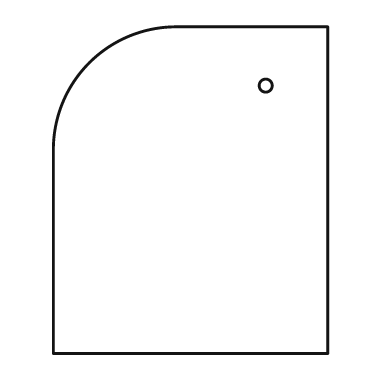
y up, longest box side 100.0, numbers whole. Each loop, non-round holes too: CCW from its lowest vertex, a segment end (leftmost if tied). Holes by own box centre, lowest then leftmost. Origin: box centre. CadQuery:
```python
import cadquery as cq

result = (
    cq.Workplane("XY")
    .moveTo(-42.0, -50.0)
    .lineTo(42.0, -50.0)
    .lineTo(42.0, 50.0)
    .lineTo(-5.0, 50.0)
    .threePointArc((-31.0, 39.0), (-42.0, 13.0))
    .close()
    .moveTo(23.0, 32.0)
    .circle(2.0)
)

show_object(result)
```